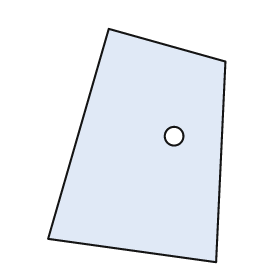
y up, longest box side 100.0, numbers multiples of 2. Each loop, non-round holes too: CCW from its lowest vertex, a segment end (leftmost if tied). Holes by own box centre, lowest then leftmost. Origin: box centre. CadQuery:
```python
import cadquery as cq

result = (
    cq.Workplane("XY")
    .moveTo(34.0, -50.0)
    .lineTo(38.0, 36.0)
    .lineTo(-12.0, 50.0)
    .lineTo(-38.0, -40.0)
    .close()
    .moveTo(16.0, 4.0)
    .circle(4.0)
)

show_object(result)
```